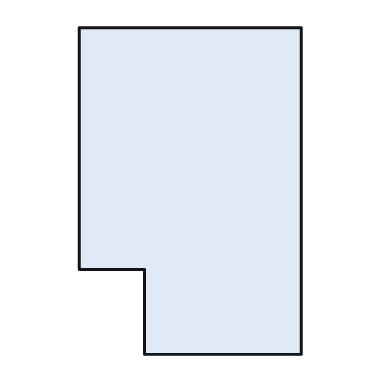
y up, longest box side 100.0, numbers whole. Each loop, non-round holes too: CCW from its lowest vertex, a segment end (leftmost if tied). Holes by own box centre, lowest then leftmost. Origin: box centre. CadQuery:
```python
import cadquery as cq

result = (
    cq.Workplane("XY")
    .moveTo(-14.0, -50.0)
    .lineTo(34.0, -50.0)
    .lineTo(34.0, 50.0)
    .lineTo(-34.0, 50.0)
    .lineTo(-34.0, -24.0)
    .lineTo(-14.0, -24.0)
    .close()
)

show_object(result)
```